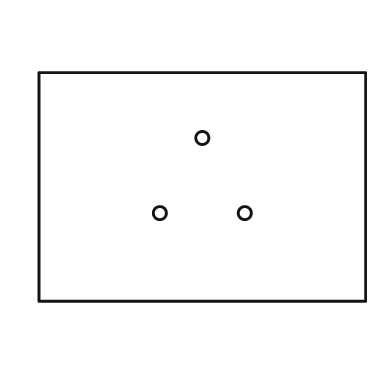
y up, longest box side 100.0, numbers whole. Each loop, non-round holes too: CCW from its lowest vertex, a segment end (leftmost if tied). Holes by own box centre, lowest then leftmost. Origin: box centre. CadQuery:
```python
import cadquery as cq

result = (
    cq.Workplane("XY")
    .moveTo(-50.0, -35.0)
    .lineTo(50.0, -35.0)
    .lineTo(50.0, 35.0)
    .lineTo(-50.0, 35.0)
    .close()
    .moveTo(-13.0, -8.0)
    .circle(2.0)
    .moveTo(13.0, -8.0)
    .circle(2.0)
    .moveTo(0.0, 15.0)
    .circle(2.0)
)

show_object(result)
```